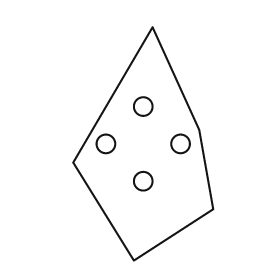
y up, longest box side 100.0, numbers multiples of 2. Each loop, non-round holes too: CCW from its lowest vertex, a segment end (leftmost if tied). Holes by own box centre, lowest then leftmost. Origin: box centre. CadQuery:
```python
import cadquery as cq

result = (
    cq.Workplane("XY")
    .moveTo(-4.0, -50.0)
    .lineTo(30.0, -28.0)
    .lineTo(24.0, 6.0)
    .lineTo(4.0, 50.0)
    .lineTo(-30.0, -8.0)
    .close()
    .moveTo(0.0, -16.0)
    .circle(4.0)
    .moveTo(-16.0, 0.0)
    .circle(4.0)
    .moveTo(16.0, 0.0)
    .circle(4.0)
    .moveTo(0.0, 16.0)
    .circle(4.0)
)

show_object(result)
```